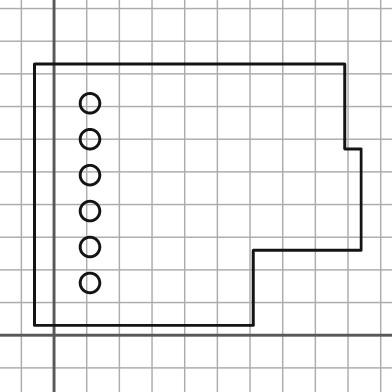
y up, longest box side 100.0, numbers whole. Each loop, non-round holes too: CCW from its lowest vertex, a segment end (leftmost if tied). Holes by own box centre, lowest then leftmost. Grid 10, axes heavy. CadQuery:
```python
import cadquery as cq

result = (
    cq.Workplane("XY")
    .moveTo(-6.0, 3.0)
    .lineTo(61.0, 3.0)
    .lineTo(61.0, 26.0)
    .lineTo(94.0, 26.0)
    .lineTo(94.0, 57.0)
    .lineTo(89.0, 57.0)
    .lineTo(89.0, 83.0)
    .lineTo(-6.0, 83.0)
    .close()
    .moveTo(11.0, 16.0)
    .circle(3.0)
    .moveTo(11.0, 27.0)
    .circle(3.0)
    .moveTo(11.0, 38.0)
    .circle(3.0)
    .moveTo(11.0, 49.0)
    .circle(3.0)
    .moveTo(11.0, 60.0)
    .circle(3.0)
    .moveTo(11.0, 71.0)
    .circle(3.0)
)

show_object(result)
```